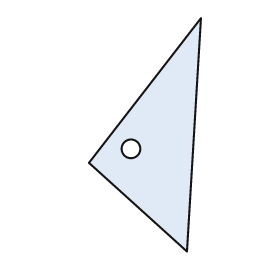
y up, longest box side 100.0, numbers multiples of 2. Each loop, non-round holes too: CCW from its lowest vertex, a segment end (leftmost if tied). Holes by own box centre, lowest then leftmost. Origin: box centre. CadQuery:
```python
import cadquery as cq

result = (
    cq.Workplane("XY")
    .moveTo(18.0, -50.0)
    .lineTo(24.0, 50.0)
    .lineTo(-24.0, -12.0)
    .close()
    .moveTo(-6.0, -6.0)
    .circle(4.0)
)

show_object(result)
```